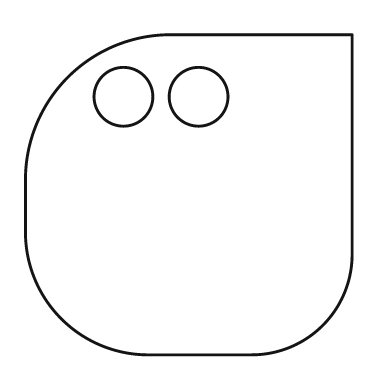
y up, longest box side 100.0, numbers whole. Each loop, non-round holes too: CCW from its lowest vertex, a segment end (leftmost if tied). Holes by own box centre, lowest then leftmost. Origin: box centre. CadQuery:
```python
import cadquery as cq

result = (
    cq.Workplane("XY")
    .moveTo(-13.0, -49.0)
    .lineTo(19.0, -49.0)
    .threePointArc((41.0, -40.0), (50.0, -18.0))
    .lineTo(50.0, 49.0)
    .lineTo(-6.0, 49.0)
    .threePointArc((-37.0, 36.0), (-50.0, 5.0))
    .lineTo(-50.0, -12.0)
    .threePointArc((-39.0, -38.0), (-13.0, -49.0))
    .close()
    .moveTo(-20.0, 30.0)
    .circle(9.0)
    .moveTo(3.0, 30.0)
    .circle(9.0)
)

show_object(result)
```